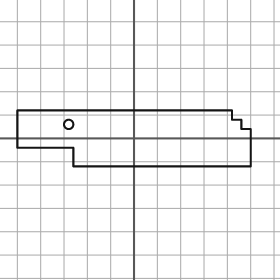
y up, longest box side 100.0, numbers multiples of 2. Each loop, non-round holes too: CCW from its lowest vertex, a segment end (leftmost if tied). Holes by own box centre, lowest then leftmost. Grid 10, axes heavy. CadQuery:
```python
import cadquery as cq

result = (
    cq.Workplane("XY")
    .moveTo(-26.0, -12.0)
    .lineTo(50.0, -12.0)
    .lineTo(50.0, 4.0)
    .lineTo(46.0, 4.0)
    .lineTo(46.0, 8.0)
    .lineTo(42.0, 8.0)
    .lineTo(42.0, 12.0)
    .lineTo(-50.0, 12.0)
    .lineTo(-50.0, -4.0)
    .lineTo(-26.0, -4.0)
    .close()
    .moveTo(-28.0, 6.0)
    .circle(2.0)
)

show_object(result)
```